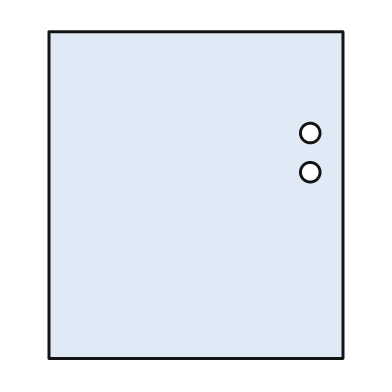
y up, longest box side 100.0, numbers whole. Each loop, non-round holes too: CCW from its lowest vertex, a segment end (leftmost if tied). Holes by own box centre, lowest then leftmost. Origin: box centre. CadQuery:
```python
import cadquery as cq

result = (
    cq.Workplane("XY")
    .moveTo(-45.0, -50.0)
    .lineTo(45.0, -50.0)
    .lineTo(45.0, 50.0)
    .lineTo(-45.0, 50.0)
    .close()
    .moveTo(35.0, 7.0)
    .circle(3.0)
    .moveTo(35.0, 19.0)
    .circle(3.0)
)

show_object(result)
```